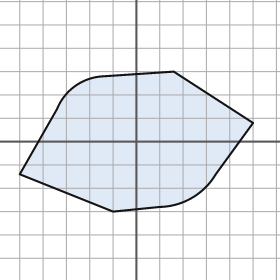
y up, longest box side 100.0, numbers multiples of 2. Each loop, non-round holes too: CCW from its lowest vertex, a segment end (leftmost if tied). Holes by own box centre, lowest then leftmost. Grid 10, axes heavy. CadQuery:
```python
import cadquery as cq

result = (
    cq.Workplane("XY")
    .moveTo(-10.0, -30.0)
    .lineTo(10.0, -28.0)
    .threePointArc((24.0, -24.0), (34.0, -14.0))
    .lineTo(50.0, 8.0)
    .lineTo(16.0, 30.0)
    .lineTo(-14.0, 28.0)
    .threePointArc((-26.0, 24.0), (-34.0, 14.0))
    .lineTo(-50.0, -14.0)
    .close()
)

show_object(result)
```